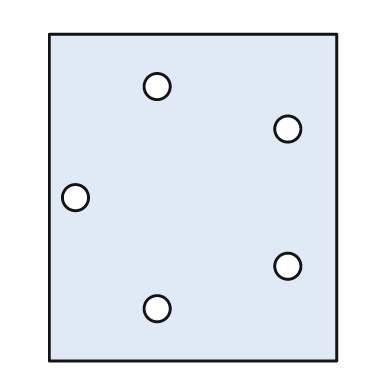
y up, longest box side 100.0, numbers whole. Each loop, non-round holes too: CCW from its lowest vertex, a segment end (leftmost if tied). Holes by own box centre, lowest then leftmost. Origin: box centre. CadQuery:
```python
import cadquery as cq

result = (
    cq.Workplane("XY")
    .moveTo(-44.0, -50.0)
    .lineTo(44.0, -50.0)
    .lineTo(44.0, 50.0)
    .lineTo(-44.0, 50.0)
    .close()
    .moveTo(-11.0, -34.0)
    .circle(4.0)
    .moveTo(29.0, -21.0)
    .circle(4.0)
    .moveTo(-36.0, 0.0)
    .circle(4.0)
    .moveTo(29.0, 21.0)
    .circle(4.0)
    .moveTo(-11.0, 34.0)
    .circle(4.0)
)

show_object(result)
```